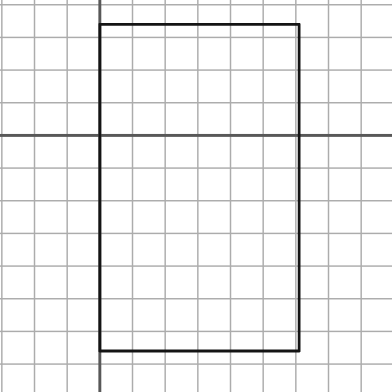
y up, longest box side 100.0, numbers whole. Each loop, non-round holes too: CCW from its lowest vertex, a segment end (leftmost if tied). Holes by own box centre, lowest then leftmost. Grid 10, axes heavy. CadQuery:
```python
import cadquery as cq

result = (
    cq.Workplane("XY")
    .moveTo(0.0, -66.0)
    .lineTo(61.0, -66.0)
    .lineTo(61.0, 34.0)
    .lineTo(0.0, 34.0)
    .close()
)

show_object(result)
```